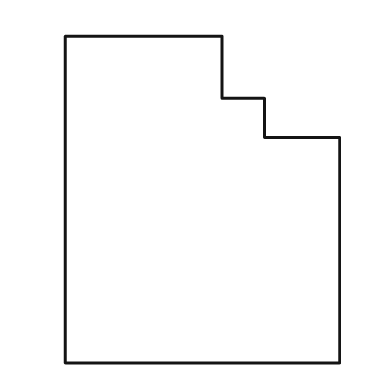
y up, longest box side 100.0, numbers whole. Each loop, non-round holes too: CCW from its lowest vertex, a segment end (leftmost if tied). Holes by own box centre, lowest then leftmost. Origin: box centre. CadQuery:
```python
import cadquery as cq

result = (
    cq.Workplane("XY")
    .moveTo(-42.0, -50.0)
    .lineTo(42.0, -50.0)
    .lineTo(42.0, 19.0)
    .lineTo(19.0, 19.0)
    .lineTo(19.0, 31.0)
    .lineTo(6.0, 31.0)
    .lineTo(6.0, 50.0)
    .lineTo(-42.0, 50.0)
    .close()
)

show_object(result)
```